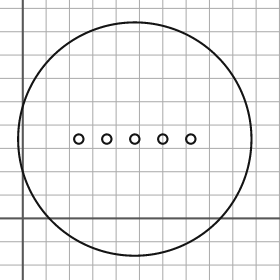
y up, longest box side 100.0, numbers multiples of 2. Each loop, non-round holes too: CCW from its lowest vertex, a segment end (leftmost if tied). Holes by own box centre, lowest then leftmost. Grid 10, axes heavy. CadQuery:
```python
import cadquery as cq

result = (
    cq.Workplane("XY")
    .moveTo(48.0, 34.0)
    .circle(50.0)
    .moveTo(24.0, 34.0)
    .circle(2.0)
    .moveTo(36.0, 34.0)
    .circle(2.0)
    .moveTo(48.0, 34.0)
    .circle(2.0)
    .moveTo(60.0, 34.0)
    .circle(2.0)
    .moveTo(72.0, 34.0)
    .circle(2.0)
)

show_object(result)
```